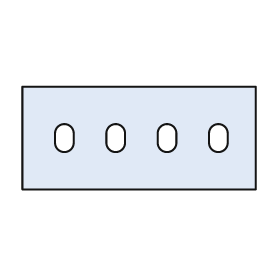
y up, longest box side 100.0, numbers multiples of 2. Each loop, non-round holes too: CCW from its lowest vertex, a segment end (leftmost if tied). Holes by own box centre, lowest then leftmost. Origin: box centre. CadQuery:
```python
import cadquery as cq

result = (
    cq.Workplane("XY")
    .moveTo(-50.0, -22.0)
    .lineTo(50.0, -22.0)
    .lineTo(50.0, 22.0)
    .lineTo(-50.0, 22.0)
    .close()
    .moveTo(-36.0, -2.0)
    .threePointArc((-32.0, -6.0), (-28.0, -2.0))
    .lineTo(-28.0, 2.0)
    .threePointArc((-32.0, 6.0), (-36.0, 2.0))
    .close()
    .moveTo(-14.0, -2.0)
    .threePointArc((-10.0, -6.0), (-6.0, -2.0))
    .lineTo(-6.0, 2.0)
    .threePointArc((-10.0, 6.0), (-14.0, 2.0))
    .close()
    .moveTo(8.0, -2.0)
    .threePointArc((12.0, -6.0), (16.0, -2.0))
    .lineTo(16.0, 2.0)
    .threePointArc((12.0, 6.0), (8.0, 2.0))
    .close()
    .moveTo(30.0, -2.0)
    .threePointArc((34.0, -6.0), (38.0, -2.0))
    .lineTo(38.0, 2.0)
    .threePointArc((34.0, 6.0), (30.0, 2.0))
    .close()
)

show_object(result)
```